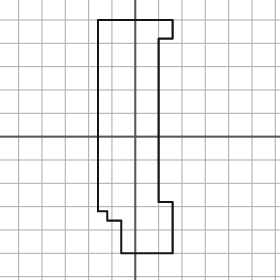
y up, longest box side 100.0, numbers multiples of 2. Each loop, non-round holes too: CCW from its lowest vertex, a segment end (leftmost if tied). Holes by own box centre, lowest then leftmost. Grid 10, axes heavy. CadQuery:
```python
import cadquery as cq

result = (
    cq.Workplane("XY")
    .moveTo(-6.0, -50.0)
    .lineTo(16.0, -50.0)
    .lineTo(16.0, -28.0)
    .lineTo(10.0, -28.0)
    .lineTo(10.0, 42.0)
    .lineTo(16.0, 42.0)
    .lineTo(16.0, 50.0)
    .lineTo(-16.0, 50.0)
    .lineTo(-16.0, -32.0)
    .lineTo(-12.0, -32.0)
    .lineTo(-12.0, -36.0)
    .lineTo(-6.0, -36.0)
    .close()
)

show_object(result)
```